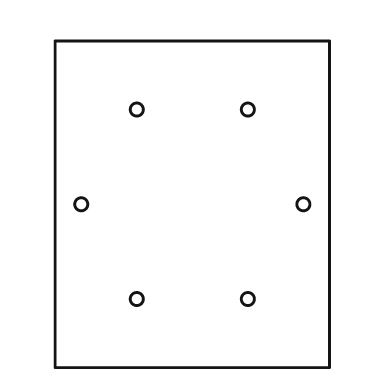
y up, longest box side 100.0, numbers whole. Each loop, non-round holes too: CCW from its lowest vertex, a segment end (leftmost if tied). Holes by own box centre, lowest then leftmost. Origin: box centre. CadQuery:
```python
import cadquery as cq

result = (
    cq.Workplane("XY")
    .moveTo(-42.0, -50.0)
    .lineTo(42.0, -50.0)
    .lineTo(42.0, 50.0)
    .lineTo(-42.0, 50.0)
    .close()
    .moveTo(-17.0, -29.0)
    .circle(2.0)
    .moveTo(17.0, -29.0)
    .circle(2.0)
    .moveTo(-34.0, 0.0)
    .circle(2.0)
    .moveTo(34.0, 0.0)
    .circle(2.0)
    .moveTo(-17.0, 29.0)
    .circle(2.0)
    .moveTo(17.0, 29.0)
    .circle(2.0)
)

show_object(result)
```